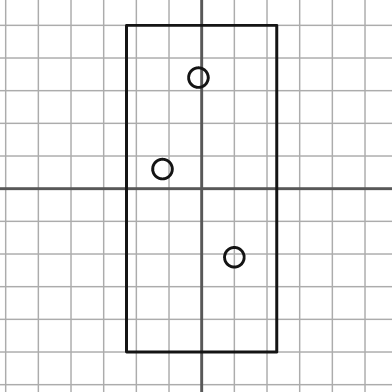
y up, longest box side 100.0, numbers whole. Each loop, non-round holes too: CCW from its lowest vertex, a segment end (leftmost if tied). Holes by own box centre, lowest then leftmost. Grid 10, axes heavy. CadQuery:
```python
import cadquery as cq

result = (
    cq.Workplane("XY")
    .moveTo(-23.0, -50.0)
    .lineTo(23.0, -50.0)
    .lineTo(23.0, 50.0)
    .lineTo(-23.0, 50.0)
    .close()
    .moveTo(10.0, -21.0)
    .circle(3.0)
    .moveTo(-12.0, 6.0)
    .circle(3.0)
    .moveTo(-1.0, 34.0)
    .circle(3.0)
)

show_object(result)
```